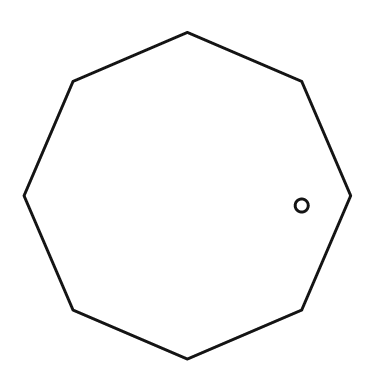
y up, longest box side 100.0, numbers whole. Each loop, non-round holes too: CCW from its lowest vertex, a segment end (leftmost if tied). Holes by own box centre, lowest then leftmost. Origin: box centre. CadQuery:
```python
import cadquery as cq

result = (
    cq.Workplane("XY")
    .moveTo(0.0, -50.0)
    .lineTo(35.0, -35.0)
    .lineTo(50.0, 0.0)
    .lineTo(35.0, 35.0)
    .lineTo(0.0, 50.0)
    .lineTo(-35.0, 35.0)
    .lineTo(-50.0, 0.0)
    .lineTo(-35.0, -35.0)
    .close()
    .moveTo(35.0, -3.0)
    .circle(2.0)
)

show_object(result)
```